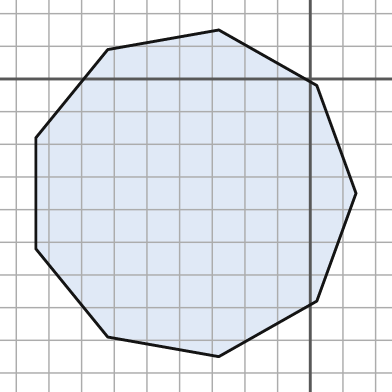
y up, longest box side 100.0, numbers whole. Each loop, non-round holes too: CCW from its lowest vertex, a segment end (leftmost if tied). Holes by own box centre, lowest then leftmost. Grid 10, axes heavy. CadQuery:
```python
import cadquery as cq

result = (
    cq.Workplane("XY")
    .moveTo(-28.0, -85.0)
    .lineTo(2.0, -68.0)
    .lineTo(14.0, -35.0)
    .lineTo(2.0, -2.0)
    .lineTo(-28.0, 15.0)
    .lineTo(-62.0, 9.0)
    .lineTo(-84.0, -18.0)
    .lineTo(-84.0, -52.0)
    .lineTo(-62.0, -79.0)
    .close()
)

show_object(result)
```